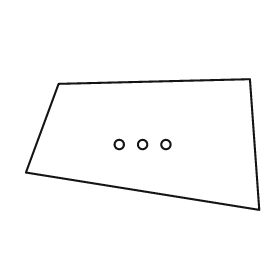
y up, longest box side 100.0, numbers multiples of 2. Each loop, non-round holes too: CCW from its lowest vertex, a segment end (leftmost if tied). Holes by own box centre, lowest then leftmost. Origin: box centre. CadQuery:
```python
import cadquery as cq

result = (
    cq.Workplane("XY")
    .moveTo(50.0, -28.0)
    .lineTo(46.0, 28.0)
    .lineTo(-36.0, 26.0)
    .lineTo(-50.0, -12.0)
    .close()
    .moveTo(-10.0, 0.0)
    .circle(2.0)
    .moveTo(0.0, 0.0)
    .circle(2.0)
    .moveTo(10.0, 0.0)
    .circle(2.0)
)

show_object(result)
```